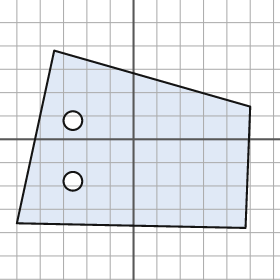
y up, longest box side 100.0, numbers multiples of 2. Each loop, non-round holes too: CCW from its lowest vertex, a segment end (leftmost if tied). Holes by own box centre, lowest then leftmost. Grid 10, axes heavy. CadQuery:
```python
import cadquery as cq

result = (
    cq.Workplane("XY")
    .moveTo(48.0, -38.0)
    .lineTo(50.0, 14.0)
    .lineTo(-34.0, 38.0)
    .lineTo(-50.0, -36.0)
    .close()
    .moveTo(-26.0, -18.0)
    .circle(4.0)
    .moveTo(-26.0, 8.0)
    .circle(4.0)
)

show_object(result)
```